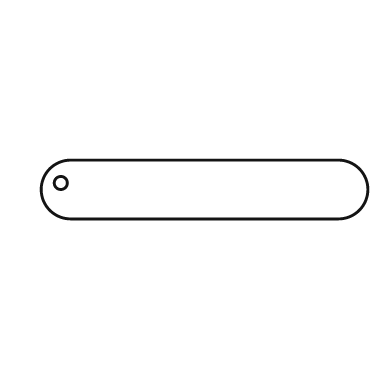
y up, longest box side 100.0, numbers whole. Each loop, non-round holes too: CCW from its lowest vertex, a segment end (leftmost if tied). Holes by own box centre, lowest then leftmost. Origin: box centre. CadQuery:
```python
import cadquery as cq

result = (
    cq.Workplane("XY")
    .moveTo(-41.0, -9.0)
    .lineTo(41.0, -9.0)
    .threePointArc((50.0, 0.0), (41.0, 9.0))
    .lineTo(-41.0, 9.0)
    .threePointArc((-50.0, 0.0), (-41.0, -9.0))
    .close()
    .moveTo(-44.0, 2.0)
    .circle(2.0)
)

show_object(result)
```